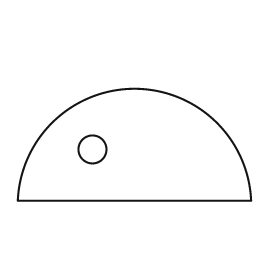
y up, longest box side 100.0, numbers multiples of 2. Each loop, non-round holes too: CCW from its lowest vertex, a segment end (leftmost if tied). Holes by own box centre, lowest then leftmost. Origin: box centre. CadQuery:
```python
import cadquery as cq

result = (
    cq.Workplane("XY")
    .moveTo(-50.0, -24.0)
    .lineTo(50.0, -24.0)
    .threePointArc((0.0, 24.0), (-50.0, -24.0))
    .close()
    .moveTo(-18.0, -2.0)
    .circle(6.0)
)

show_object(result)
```